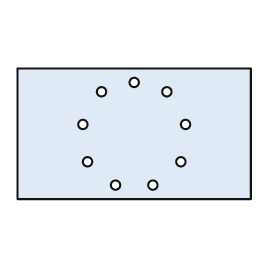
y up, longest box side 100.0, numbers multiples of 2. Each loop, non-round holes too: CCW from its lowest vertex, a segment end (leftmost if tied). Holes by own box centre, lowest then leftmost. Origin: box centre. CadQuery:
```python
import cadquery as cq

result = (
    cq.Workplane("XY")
    .moveTo(-50.0, -28.0)
    .lineTo(50.0, -28.0)
    .lineTo(50.0, 28.0)
    .lineTo(-50.0, 28.0)
    .close()
    .moveTo(-8.0, -22.0)
    .circle(2.0)
    .moveTo(8.0, -22.0)
    .circle(2.0)
    .moveTo(-20.0, -12.0)
    .circle(2.0)
    .moveTo(20.0, -12.0)
    .circle(2.0)
    .moveTo(-22.0, 4.0)
    .circle(2.0)
    .moveTo(22.0, 4.0)
    .circle(2.0)
    .moveTo(-14.0, 18.0)
    .circle(2.0)
    .moveTo(14.0, 18.0)
    .circle(2.0)
    .moveTo(0.0, 22.0)
    .circle(2.0)
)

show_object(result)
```